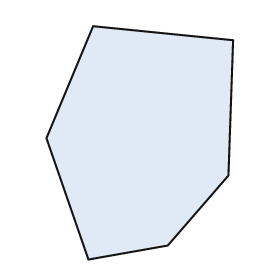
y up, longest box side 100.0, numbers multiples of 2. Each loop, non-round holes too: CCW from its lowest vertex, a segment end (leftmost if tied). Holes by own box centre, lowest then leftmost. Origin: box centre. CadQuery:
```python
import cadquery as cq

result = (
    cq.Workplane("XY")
    .moveTo(-22.0, -50.0)
    .lineTo(12.0, -44.0)
    .lineTo(38.0, -14.0)
    .lineTo(40.0, 44.0)
    .lineTo(-20.0, 50.0)
    .lineTo(-40.0, 2.0)
    .close()
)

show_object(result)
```